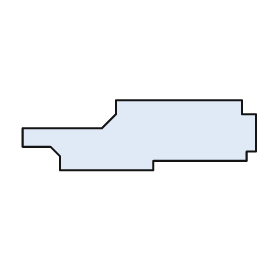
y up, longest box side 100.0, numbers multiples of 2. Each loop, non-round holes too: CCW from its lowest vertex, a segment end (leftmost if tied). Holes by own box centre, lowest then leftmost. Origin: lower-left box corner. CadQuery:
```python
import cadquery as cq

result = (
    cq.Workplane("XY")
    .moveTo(16.0, 0.0)
    .lineTo(56.0, 0.0)
    .lineTo(56.0, 4.0)
    .lineTo(96.0, 4.0)
    .lineTo(96.0, 8.0)
    .lineTo(100.0, 8.0)
    .lineTo(100.0, 24.0)
    .lineTo(94.0, 24.0)
    .lineTo(94.0, 30.0)
    .lineTo(40.0, 30.0)
    .lineTo(40.0, 24.0)
    .lineTo(34.0, 18.0)
    .lineTo(0.0, 18.0)
    .lineTo(0.0, 10.0)
    .lineTo(12.0, 10.0)
    .lineTo(16.0, 6.0)
    .close()
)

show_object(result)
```